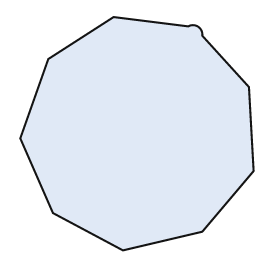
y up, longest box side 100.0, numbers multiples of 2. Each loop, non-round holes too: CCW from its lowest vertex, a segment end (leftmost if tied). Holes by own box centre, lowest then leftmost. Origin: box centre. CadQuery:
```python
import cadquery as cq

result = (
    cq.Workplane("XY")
    .moveTo(-6.0, -50.0)
    .lineTo(28.0, -42.0)
    .lineTo(50.0, -16.0)
    .lineTo(48.0, 20.0)
    .lineTo(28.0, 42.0)
    .threePointArc((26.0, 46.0), (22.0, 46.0))
    .lineTo(-10.0, 50.0)
    .lineTo(-38.0, 32.0)
    .lineTo(-50.0, -2.0)
    .lineTo(-36.0, -34.0)
    .close()
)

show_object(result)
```